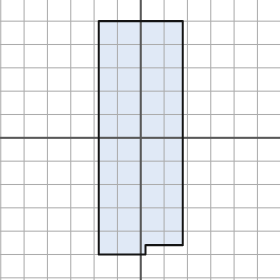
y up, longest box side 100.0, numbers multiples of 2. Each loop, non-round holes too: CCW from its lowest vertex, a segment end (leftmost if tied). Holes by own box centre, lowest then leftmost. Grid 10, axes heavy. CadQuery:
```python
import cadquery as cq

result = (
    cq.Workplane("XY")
    .moveTo(-18.0, -50.0)
    .lineTo(2.0, -50.0)
    .lineTo(2.0, -46.0)
    .lineTo(18.0, -46.0)
    .lineTo(18.0, 50.0)
    .lineTo(-18.0, 50.0)
    .close()
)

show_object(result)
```